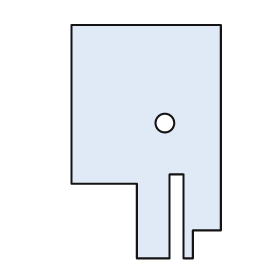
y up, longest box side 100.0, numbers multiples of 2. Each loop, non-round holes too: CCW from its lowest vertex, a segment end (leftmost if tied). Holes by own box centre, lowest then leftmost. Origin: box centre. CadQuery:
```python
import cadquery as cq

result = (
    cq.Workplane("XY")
    .moveTo(-4.0, -50.0)
    .lineTo(10.0, -50.0)
    .lineTo(10.0, -14.0)
    .lineTo(16.0, -14.0)
    .lineTo(16.0, -50.0)
    .lineTo(20.0, -50.0)
    .lineTo(20.0, -38.0)
    .lineTo(32.0, -38.0)
    .lineTo(32.0, 50.0)
    .lineTo(-32.0, 50.0)
    .lineTo(-32.0, -18.0)
    .lineTo(-4.0, -18.0)
    .close()
    .moveTo(8.0, 8.0)
    .circle(4.0)
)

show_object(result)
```